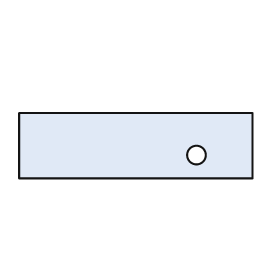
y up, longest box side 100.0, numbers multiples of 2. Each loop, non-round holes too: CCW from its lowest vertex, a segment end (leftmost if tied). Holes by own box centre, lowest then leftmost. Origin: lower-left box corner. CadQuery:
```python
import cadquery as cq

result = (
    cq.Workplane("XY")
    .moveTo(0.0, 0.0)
    .lineTo(100.0, 0.0)
    .lineTo(100.0, 28.0)
    .lineTo(0.0, 28.0)
    .close()
    .moveTo(76.0, 10.0)
    .circle(4.0)
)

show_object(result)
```